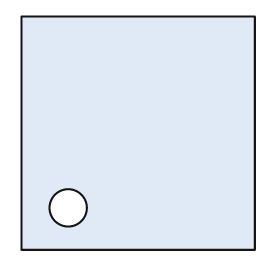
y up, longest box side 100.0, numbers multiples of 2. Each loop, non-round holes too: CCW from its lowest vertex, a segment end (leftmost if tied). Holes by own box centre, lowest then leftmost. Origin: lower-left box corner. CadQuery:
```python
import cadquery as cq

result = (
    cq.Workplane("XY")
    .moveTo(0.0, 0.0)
    .lineTo(100.0, 0.0)
    .lineTo(100.0, 100.0)
    .lineTo(0.0, 100.0)
    .close()
    .moveTo(20.0, 18.0)
    .circle(8.0)
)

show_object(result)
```